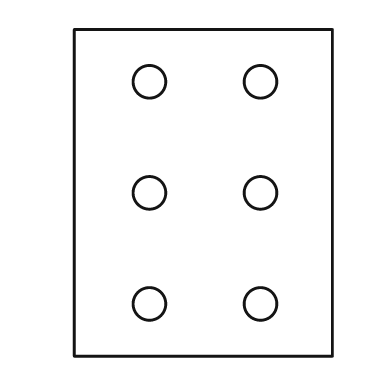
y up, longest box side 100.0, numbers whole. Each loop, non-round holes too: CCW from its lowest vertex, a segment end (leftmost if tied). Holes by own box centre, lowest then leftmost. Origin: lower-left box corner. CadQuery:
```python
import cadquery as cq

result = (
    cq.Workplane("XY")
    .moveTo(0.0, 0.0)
    .lineTo(79.0, 0.0)
    .lineTo(79.0, 100.0)
    .lineTo(0.0, 100.0)
    .close()
    .moveTo(23.0, 16.0)
    .circle(5.0)
    .moveTo(57.0, 16.0)
    .circle(5.0)
    .moveTo(23.0, 50.0)
    .circle(5.0)
    .moveTo(57.0, 50.0)
    .circle(5.0)
    .moveTo(23.0, 84.0)
    .circle(5.0)
    .moveTo(57.0, 84.0)
    .circle(5.0)
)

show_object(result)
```